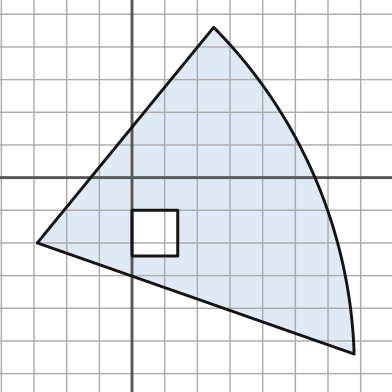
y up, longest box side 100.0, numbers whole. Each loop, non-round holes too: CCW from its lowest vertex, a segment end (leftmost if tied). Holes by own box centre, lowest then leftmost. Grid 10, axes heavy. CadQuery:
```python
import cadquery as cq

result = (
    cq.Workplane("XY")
    .moveTo(68.0, -54.0)
    .threePointArc((56.0, 0.0), (25.0, 46.0))
    .lineTo(-29.0, -20.0)
    .close()
    .moveTo(0.0, -24.0)
    .lineTo(14.0, -24.0)
    .lineTo(14.0, -10.0)
    .lineTo(0.0, -10.0)
    .close()
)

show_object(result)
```